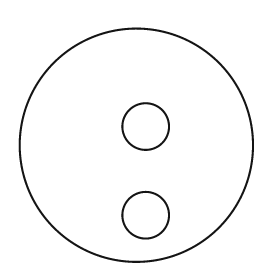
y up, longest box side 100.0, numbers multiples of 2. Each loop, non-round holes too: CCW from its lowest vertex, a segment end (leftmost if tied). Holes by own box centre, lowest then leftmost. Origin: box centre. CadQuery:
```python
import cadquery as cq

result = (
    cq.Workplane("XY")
    .moveTo(0.0, 0.0)
    .circle(50.0)
    .moveTo(4.0, -30.0)
    .circle(10.0)
    .moveTo(4.0, 8.0)
    .circle(10.0)
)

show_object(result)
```